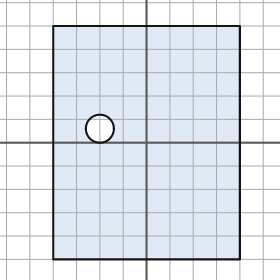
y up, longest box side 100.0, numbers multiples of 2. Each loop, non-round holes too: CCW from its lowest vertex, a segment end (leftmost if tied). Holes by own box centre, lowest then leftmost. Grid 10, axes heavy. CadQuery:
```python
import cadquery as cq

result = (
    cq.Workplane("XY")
    .moveTo(-40.0, -50.0)
    .lineTo(40.0, -50.0)
    .lineTo(40.0, 50.0)
    .lineTo(-40.0, 50.0)
    .close()
    .moveTo(-20.0, 6.0)
    .circle(6.0)
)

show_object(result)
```